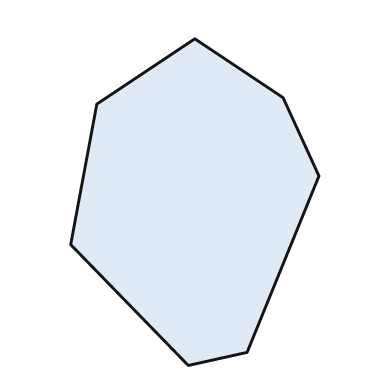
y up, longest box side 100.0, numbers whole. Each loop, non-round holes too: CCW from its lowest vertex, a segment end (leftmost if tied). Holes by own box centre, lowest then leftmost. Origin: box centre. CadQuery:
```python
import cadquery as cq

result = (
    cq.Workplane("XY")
    .moveTo(-2.0, -50.0)
    .lineTo(16.0, -46.0)
    .lineTo(38.0, 8.0)
    .lineTo(27.0, 32.0)
    .lineTo(0.0, 50.0)
    .lineTo(-30.0, 30.0)
    .lineTo(-38.0, -13.0)
    .close()
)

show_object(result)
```